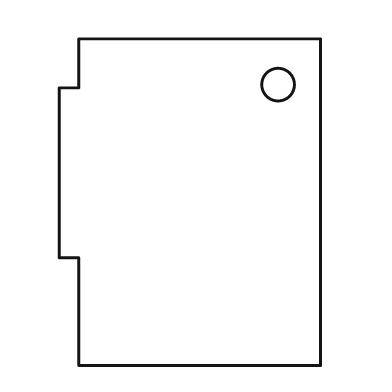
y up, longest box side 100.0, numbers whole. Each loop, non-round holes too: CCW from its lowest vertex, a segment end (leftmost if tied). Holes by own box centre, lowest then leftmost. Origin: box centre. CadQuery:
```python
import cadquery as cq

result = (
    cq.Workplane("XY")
    .moveTo(-34.0, -50.0)
    .lineTo(40.0, -50.0)
    .lineTo(40.0, 50.0)
    .lineTo(-34.0, 50.0)
    .lineTo(-34.0, 35.0)
    .lineTo(-40.0, 35.0)
    .lineTo(-40.0, -17.0)
    .lineTo(-34.0, -17.0)
    .close()
    .moveTo(27.0, 36.0)
    .circle(5.0)
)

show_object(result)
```